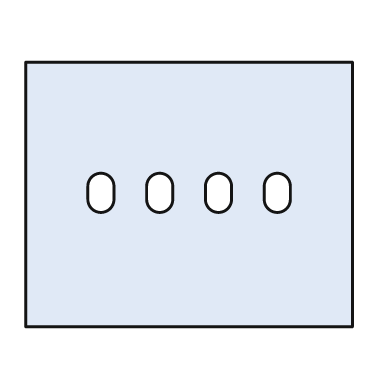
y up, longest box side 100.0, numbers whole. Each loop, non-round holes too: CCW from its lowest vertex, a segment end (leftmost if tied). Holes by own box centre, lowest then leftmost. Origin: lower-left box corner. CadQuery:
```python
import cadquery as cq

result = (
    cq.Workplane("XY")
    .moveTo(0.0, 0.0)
    .lineTo(100.0, 0.0)
    .lineTo(100.0, 81.0)
    .lineTo(0.0, 81.0)
    .close()
    .moveTo(19.0, 39.0)
    .threePointArc((23.0, 35.0), (27.0, 39.0))
    .lineTo(27.0, 43.0)
    .threePointArc((23.0, 47.0), (19.0, 43.0))
    .close()
    .moveTo(37.0, 39.0)
    .threePointArc((41.0, 35.0), (45.0, 39.0))
    .lineTo(45.0, 43.0)
    .threePointArc((41.0, 47.0), (37.0, 43.0))
    .close()
    .moveTo(55.0, 39.0)
    .threePointArc((59.0, 35.0), (63.0, 39.0))
    .lineTo(63.0, 43.0)
    .threePointArc((59.0, 47.0), (55.0, 43.0))
    .close()
    .moveTo(73.0, 39.0)
    .threePointArc((77.0, 35.0), (81.0, 39.0))
    .lineTo(81.0, 43.0)
    .threePointArc((77.0, 47.0), (73.0, 43.0))
    .close()
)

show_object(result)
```